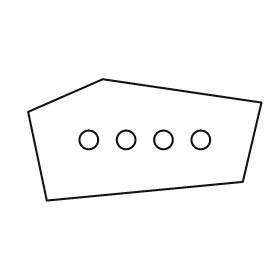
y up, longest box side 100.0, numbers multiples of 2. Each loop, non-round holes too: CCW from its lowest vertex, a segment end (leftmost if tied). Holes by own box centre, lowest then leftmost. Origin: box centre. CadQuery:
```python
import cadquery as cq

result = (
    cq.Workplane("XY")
    .moveTo(-42.0, -26.0)
    .lineTo(42.0, -18.0)
    .lineTo(50.0, 16.0)
    .lineTo(-18.0, 26.0)
    .lineTo(-50.0, 12.0)
    .close()
    .moveTo(-24.0, 0.0)
    .circle(4.0)
    .moveTo(-8.0, 0.0)
    .circle(4.0)
    .moveTo(8.0, 0.0)
    .circle(4.0)
    .moveTo(24.0, 0.0)
    .circle(4.0)
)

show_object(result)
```